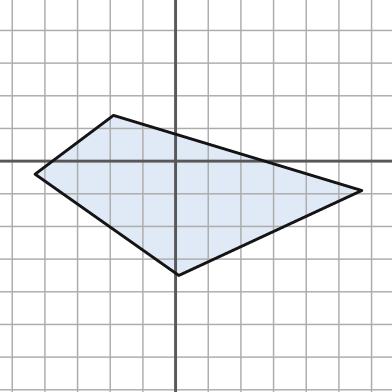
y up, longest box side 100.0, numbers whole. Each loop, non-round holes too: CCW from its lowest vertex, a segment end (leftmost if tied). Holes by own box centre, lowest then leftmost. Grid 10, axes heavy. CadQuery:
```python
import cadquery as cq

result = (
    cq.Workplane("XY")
    .moveTo(1.0, -35.0)
    .lineTo(57.0, -9.0)
    .lineTo(-19.0, 14.0)
    .lineTo(-43.0, -4.0)
    .close()
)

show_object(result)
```